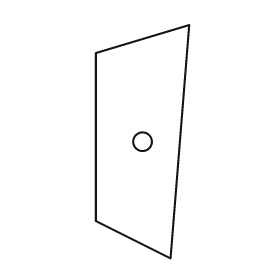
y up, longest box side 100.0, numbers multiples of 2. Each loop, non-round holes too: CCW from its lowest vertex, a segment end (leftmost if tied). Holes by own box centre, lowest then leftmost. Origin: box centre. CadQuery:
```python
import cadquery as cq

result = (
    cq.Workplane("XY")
    .moveTo(12.0, -50.0)
    .lineTo(20.0, 50.0)
    .lineTo(-20.0, 38.0)
    .lineTo(-20.0, -34.0)
    .close()
    .moveTo(0.0, 0.0)
    .circle(4.0)
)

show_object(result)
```